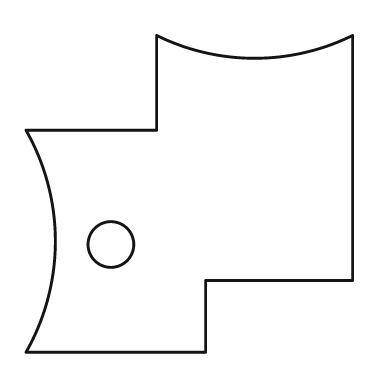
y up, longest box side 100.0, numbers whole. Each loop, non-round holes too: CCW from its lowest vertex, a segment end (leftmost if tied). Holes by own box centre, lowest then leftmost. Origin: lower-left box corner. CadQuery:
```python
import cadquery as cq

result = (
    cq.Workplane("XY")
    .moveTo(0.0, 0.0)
    .lineTo(55.0, 0.0)
    .lineTo(55.0, 22.0)
    .lineTo(100.0, 22.0)
    .lineTo(100.0, 97.0)
    .threePointArc((70.0, 90.0), (40.0, 97.0))
    .lineTo(40.0, 68.0)
    .lineTo(0.0, 68.0)
    .threePointArc((9.0, 34.0), (0.0, 0.0))
    .close()
    .moveTo(26.0, 33.0)
    .circle(7.0)
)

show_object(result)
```